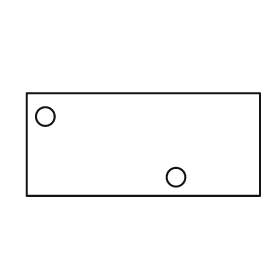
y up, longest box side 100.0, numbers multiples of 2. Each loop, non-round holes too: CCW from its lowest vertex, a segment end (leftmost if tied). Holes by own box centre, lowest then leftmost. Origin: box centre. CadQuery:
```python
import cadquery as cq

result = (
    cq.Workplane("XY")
    .moveTo(-50.0, -22.0)
    .lineTo(50.0, -22.0)
    .lineTo(50.0, 22.0)
    .lineTo(-50.0, 22.0)
    .close()
    .moveTo(14.0, -14.0)
    .circle(4.0)
    .moveTo(-42.0, 12.0)
    .circle(4.0)
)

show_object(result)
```